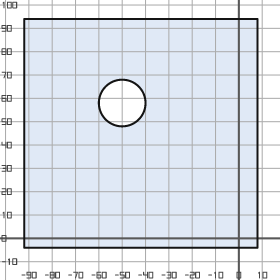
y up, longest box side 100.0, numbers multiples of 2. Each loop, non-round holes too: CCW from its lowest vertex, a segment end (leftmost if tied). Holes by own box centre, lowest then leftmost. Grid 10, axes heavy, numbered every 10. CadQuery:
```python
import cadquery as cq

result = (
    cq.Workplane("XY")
    .moveTo(-92.0, -4.0)
    .lineTo(8.0, -4.0)
    .lineTo(8.0, 94.0)
    .lineTo(-92.0, 94.0)
    .close()
    .moveTo(-50.0, 58.0)
    .circle(10.0)
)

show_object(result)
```